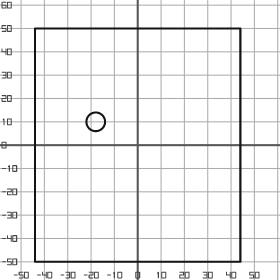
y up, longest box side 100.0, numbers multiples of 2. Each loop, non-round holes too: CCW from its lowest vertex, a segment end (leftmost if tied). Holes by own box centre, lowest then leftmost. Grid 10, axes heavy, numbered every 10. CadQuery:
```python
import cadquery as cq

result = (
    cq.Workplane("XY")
    .moveTo(-44.0, -50.0)
    .lineTo(44.0, -50.0)
    .lineTo(44.0, 50.0)
    .lineTo(-44.0, 50.0)
    .close()
    .moveTo(-18.0, 10.0)
    .circle(4.0)
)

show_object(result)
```